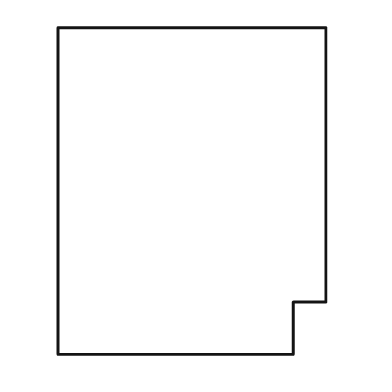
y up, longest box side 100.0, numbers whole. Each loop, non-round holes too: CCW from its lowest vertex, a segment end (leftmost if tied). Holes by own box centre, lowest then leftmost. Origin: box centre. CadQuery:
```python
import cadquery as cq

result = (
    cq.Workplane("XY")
    .moveTo(-41.0, -50.0)
    .lineTo(31.0, -50.0)
    .lineTo(31.0, -34.0)
    .lineTo(41.0, -34.0)
    .lineTo(41.0, 50.0)
    .lineTo(-41.0, 50.0)
    .close()
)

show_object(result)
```